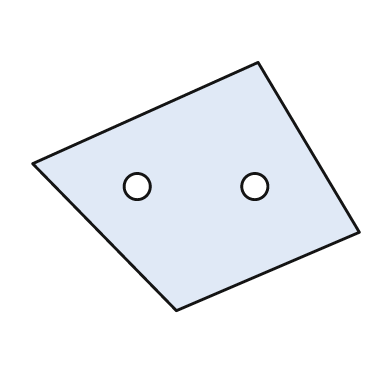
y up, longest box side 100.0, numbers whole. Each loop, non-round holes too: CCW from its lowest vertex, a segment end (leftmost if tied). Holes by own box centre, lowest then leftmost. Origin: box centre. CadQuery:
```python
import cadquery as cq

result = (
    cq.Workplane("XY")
    .moveTo(-6.0, -38.0)
    .lineTo(50.0, -14.0)
    .lineTo(19.0, 38.0)
    .lineTo(-50.0, 7.0)
    .close()
    .moveTo(-18.0, 0.0)
    .circle(4.0)
    .moveTo(18.0, 0.0)
    .circle(4.0)
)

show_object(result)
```